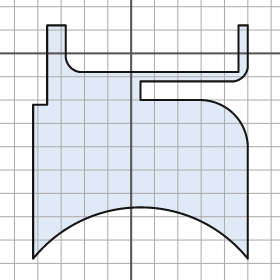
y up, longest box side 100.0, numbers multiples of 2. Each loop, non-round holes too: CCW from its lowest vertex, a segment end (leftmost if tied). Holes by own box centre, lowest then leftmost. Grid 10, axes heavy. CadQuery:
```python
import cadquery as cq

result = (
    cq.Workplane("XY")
    .moveTo(-42.0, -88.0)
    .threePointArc((4.0, -66.0), (50.0, -88.0))
    .lineTo(50.0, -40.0)
    .threePointArc((44.0, -26.0), (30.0, -20.0))
    .lineTo(4.0, -20.0)
    .lineTo(4.0, -12.0)
    .lineTo(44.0, -12.0)
    .threePointArc((48.0, -10.0), (50.0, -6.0))
    .lineTo(50.0, 12.0)
    .lineTo(46.0, 12.0)
    .lineTo(46.0, -8.0)
    .lineTo(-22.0, -8.0)
    .threePointArc((-26.0, -6.0), (-28.0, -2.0))
    .lineTo(-28.0, 12.0)
    .lineTo(-36.0, 12.0)
    .lineTo(-36.0, -22.0)
    .lineTo(-42.0, -22.0)
    .close()
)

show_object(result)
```